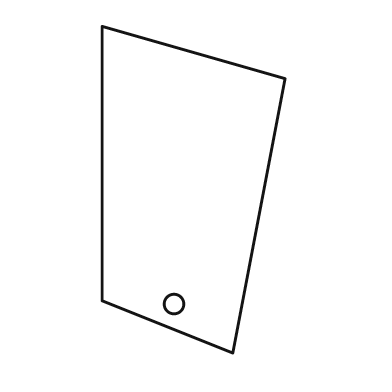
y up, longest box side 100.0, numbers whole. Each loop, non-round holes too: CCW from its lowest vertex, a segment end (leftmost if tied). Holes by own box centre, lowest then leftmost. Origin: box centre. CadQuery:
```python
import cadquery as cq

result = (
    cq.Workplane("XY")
    .moveTo(12.0, -50.0)
    .lineTo(28.0, 34.0)
    .lineTo(-28.0, 50.0)
    .lineTo(-28.0, -34.0)
    .close()
    .moveTo(-6.0, -35.0)
    .circle(3.0)
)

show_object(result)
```